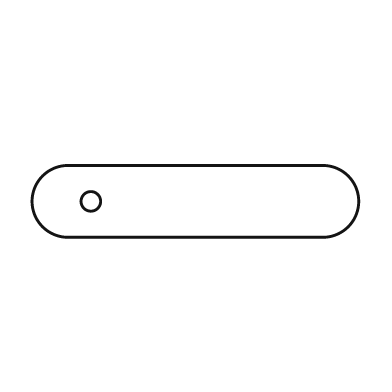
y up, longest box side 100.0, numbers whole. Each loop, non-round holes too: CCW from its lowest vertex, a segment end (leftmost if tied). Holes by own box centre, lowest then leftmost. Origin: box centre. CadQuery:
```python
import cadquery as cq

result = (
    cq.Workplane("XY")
    .moveTo(-39.0, -11.0)
    .lineTo(39.0, -11.0)
    .threePointArc((50.0, 0.0), (39.0, 11.0))
    .lineTo(-39.0, 11.0)
    .threePointArc((-50.0, 0.0), (-39.0, -11.0))
    .close()
    .moveTo(-32.0, 0.0)
    .circle(3.0)
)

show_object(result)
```